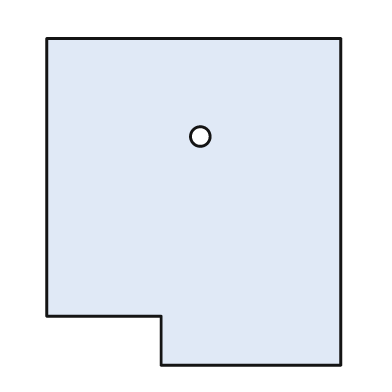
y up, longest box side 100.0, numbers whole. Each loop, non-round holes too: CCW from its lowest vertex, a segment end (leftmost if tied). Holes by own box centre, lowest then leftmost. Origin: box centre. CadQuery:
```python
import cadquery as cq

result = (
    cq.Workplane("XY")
    .moveTo(-10.0, -50.0)
    .lineTo(45.0, -50.0)
    .lineTo(45.0, 50.0)
    .lineTo(-45.0, 50.0)
    .lineTo(-45.0, -35.0)
    .lineTo(-10.0, -35.0)
    .close()
    .moveTo(2.0, 20.0)
    .circle(3.0)
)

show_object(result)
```